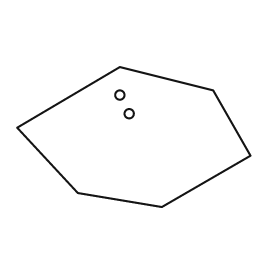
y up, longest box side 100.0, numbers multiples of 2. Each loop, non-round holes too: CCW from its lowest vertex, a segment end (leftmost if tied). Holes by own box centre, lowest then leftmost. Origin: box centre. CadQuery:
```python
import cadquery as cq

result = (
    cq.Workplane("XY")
    .moveTo(12.0, -30.0)
    .lineTo(50.0, -8.0)
    .lineTo(34.0, 20.0)
    .lineTo(-6.0, 30.0)
    .lineTo(-50.0, 4.0)
    .lineTo(-24.0, -24.0)
    .close()
    .moveTo(-2.0, 10.0)
    .circle(2.0)
    .moveTo(-6.0, 18.0)
    .circle(2.0)
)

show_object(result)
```